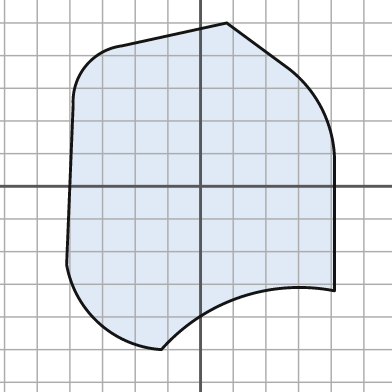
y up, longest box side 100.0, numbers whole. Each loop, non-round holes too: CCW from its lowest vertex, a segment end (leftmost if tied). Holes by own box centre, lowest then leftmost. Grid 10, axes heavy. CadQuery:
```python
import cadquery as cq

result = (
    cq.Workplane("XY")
    .moveTo(-12.0, -50.0)
    .threePointArc((12.0, -34.0), (41.0, -32.0))
    .lineTo(41.0, 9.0)
    .threePointArc((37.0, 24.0), (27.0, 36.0))
    .lineTo(8.0, 50.0)
    .lineTo(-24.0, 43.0)
    .threePointArc((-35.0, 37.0), (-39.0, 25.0))
    .lineTo(-41.0, -24.0)
    .threePointArc((-31.0, -42.0), (-12.0, -50.0))
    .close()
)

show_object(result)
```